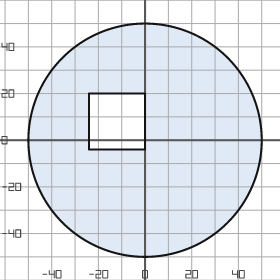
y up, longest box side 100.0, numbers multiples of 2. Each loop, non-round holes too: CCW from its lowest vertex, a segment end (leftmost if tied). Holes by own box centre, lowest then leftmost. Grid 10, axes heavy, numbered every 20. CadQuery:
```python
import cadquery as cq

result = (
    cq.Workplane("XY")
    .moveTo(0.0, 0.0)
    .circle(50.0)
    .moveTo(-24.0, -4.0)
    .lineTo(0.0, -4.0)
    .lineTo(0.0, 20.0)
    .lineTo(-24.0, 20.0)
    .close()
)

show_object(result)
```